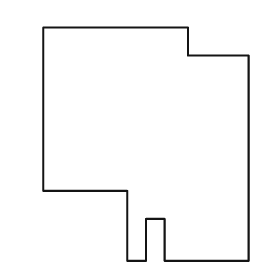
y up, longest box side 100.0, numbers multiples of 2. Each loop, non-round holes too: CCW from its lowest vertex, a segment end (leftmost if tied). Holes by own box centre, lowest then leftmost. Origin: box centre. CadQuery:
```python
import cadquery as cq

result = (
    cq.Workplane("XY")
    .moveTo(-8.0, -50.0)
    .lineTo(0.0, -50.0)
    .lineTo(0.0, -32.0)
    .lineTo(8.0, -32.0)
    .lineTo(8.0, -50.0)
    .lineTo(44.0, -50.0)
    .lineTo(44.0, 38.0)
    .lineTo(18.0, 38.0)
    .lineTo(18.0, 50.0)
    .lineTo(-44.0, 50.0)
    .lineTo(-44.0, -20.0)
    .lineTo(-8.0, -20.0)
    .close()
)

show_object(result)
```